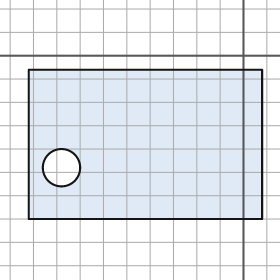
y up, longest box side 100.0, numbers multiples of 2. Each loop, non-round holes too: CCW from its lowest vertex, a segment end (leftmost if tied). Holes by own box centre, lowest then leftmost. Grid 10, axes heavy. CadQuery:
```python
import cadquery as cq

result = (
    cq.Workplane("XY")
    .moveTo(-92.0, -70.0)
    .lineTo(8.0, -70.0)
    .lineTo(8.0, -6.0)
    .lineTo(-92.0, -6.0)
    .close()
    .moveTo(-78.0, -48.0)
    .circle(8.0)
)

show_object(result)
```